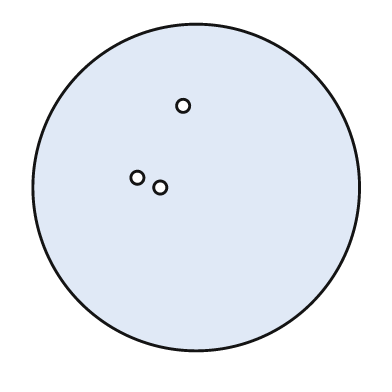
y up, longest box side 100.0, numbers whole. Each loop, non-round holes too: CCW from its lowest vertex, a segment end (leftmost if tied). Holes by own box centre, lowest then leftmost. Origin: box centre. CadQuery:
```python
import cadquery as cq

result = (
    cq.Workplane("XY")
    .moveTo(0.0, 0.0)
    .circle(50.0)
    .moveTo(-11.0, 0.0)
    .circle(2.0)
    .moveTo(-18.0, 3.0)
    .circle(2.0)
    .moveTo(-4.0, 25.0)
    .circle(2.0)
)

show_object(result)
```